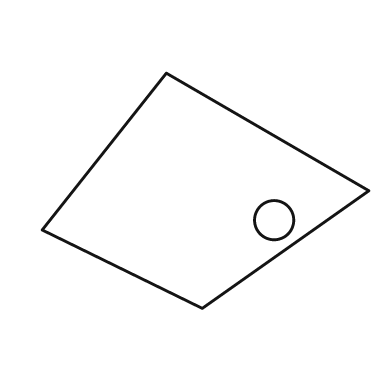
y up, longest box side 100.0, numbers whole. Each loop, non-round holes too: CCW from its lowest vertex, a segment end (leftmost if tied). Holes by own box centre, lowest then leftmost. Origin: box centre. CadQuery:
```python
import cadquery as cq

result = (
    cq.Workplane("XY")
    .moveTo(-1.0, -36.0)
    .lineTo(50.0, 0.0)
    .lineTo(-12.0, 36.0)
    .lineTo(-50.0, -12.0)
    .close()
    .moveTo(21.0, -9.0)
    .circle(6.0)
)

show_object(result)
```